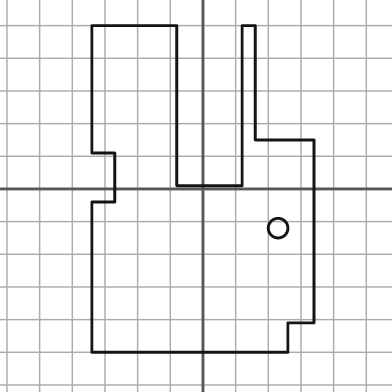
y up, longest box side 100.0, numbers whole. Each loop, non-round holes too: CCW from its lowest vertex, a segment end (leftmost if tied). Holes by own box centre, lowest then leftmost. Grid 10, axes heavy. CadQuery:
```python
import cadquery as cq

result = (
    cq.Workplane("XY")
    .moveTo(-34.0, -50.0)
    .lineTo(26.0, -50.0)
    .lineTo(26.0, -41.0)
    .lineTo(34.0, -41.0)
    .lineTo(34.0, 15.0)
    .lineTo(16.0, 15.0)
    .lineTo(16.0, 50.0)
    .lineTo(12.0, 50.0)
    .lineTo(12.0, 1.0)
    .lineTo(-8.0, 1.0)
    .lineTo(-8.0, 50.0)
    .lineTo(-34.0, 50.0)
    .lineTo(-34.0, 11.0)
    .lineTo(-27.0, 11.0)
    .lineTo(-27.0, -4.0)
    .lineTo(-34.0, -4.0)
    .close()
    .moveTo(23.0, -12.0)
    .circle(3.0)
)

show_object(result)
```